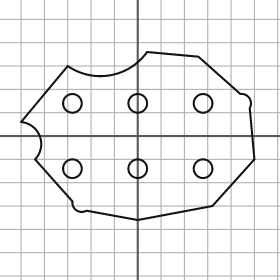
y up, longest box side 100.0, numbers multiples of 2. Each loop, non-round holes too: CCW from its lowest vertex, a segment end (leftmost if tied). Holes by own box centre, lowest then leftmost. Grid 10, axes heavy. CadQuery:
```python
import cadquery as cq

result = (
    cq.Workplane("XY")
    .moveTo(0.0, -36.0)
    .lineTo(32.0, -30.0)
    .lineTo(50.0, -10.0)
    .lineTo(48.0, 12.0)
    .threePointArc((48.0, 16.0), (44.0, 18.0))
    .lineTo(26.0, 34.0)
    .lineTo(4.0, 36.0)
    .threePointArc((-12.0, 26.0), (-30.0, 30.0))
    .lineTo(-50.0, 6.0)
    .threePointArc((-42.0, 0.0), (-44.0, -10.0))
    .lineTo(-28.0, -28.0)
    .threePointArc((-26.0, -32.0), (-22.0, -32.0))
    .close()
    .moveTo(-28.0, -14.0)
    .circle(4.0)
    .moveTo(0.0, -14.0)
    .circle(4.0)
    .moveTo(28.0, -14.0)
    .circle(4.0)
    .moveTo(-28.0, 14.0)
    .circle(4.0)
    .moveTo(0.0, 14.0)
    .circle(4.0)
    .moveTo(28.0, 14.0)
    .circle(4.0)
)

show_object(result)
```